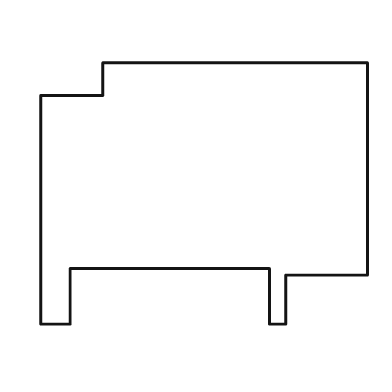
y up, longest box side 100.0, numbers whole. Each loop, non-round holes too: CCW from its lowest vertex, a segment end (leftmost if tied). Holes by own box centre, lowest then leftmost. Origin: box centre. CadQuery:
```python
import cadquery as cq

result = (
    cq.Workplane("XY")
    .moveTo(-50.0, -40.0)
    .lineTo(-41.0, -40.0)
    .lineTo(-41.0, -23.0)
    .lineTo(20.0, -23.0)
    .lineTo(20.0, -40.0)
    .lineTo(25.0, -40.0)
    .lineTo(25.0, -25.0)
    .lineTo(50.0, -25.0)
    .lineTo(50.0, 40.0)
    .lineTo(-31.0, 40.0)
    .lineTo(-31.0, 30.0)
    .lineTo(-50.0, 30.0)
    .close()
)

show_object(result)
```